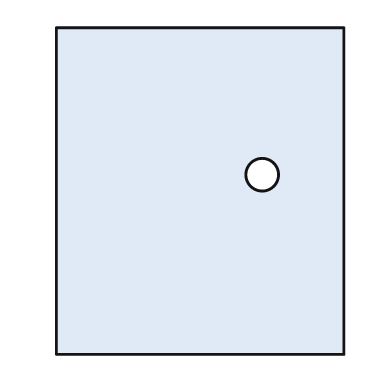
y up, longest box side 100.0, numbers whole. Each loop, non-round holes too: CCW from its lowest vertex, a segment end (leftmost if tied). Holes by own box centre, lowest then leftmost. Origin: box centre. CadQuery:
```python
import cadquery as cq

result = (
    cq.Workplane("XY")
    .moveTo(-44.0, -50.0)
    .lineTo(44.0, -50.0)
    .lineTo(44.0, 50.0)
    .lineTo(-44.0, 50.0)
    .close()
    .moveTo(19.0, 5.0)
    .circle(5.0)
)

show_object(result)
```